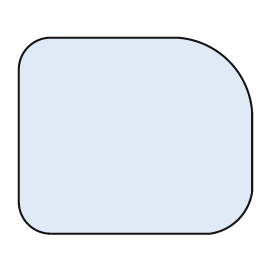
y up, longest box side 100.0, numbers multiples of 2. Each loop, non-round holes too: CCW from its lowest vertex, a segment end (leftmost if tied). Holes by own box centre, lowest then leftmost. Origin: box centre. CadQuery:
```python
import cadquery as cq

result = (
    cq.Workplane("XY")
    .moveTo(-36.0, -42.0)
    .lineTo(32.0, -42.0)
    .threePointArc((44.0, -36.0), (50.0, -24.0))
    .lineTo(50.0, 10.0)
    .threePointArc((40.0, 32.0), (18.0, 42.0))
    .lineTo(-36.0, 42.0)
    .threePointArc((-46.0, 38.0), (-50.0, 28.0))
    .lineTo(-50.0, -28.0)
    .threePointArc((-46.0, -38.0), (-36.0, -42.0))
    .close()
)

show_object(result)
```